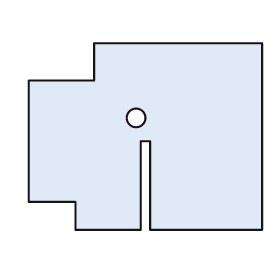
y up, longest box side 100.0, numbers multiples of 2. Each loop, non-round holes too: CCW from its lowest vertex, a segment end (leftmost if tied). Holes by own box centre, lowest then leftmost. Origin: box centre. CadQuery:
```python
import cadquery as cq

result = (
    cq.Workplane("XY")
    .moveTo(-30.0, -40.0)
    .lineTo(-2.0, -40.0)
    .lineTo(-2.0, -2.0)
    .lineTo(2.0, -2.0)
    .lineTo(2.0, -40.0)
    .lineTo(50.0, -40.0)
    .lineTo(50.0, 40.0)
    .lineTo(-22.0, 40.0)
    .lineTo(-22.0, 24.0)
    .lineTo(-50.0, 24.0)
    .lineTo(-50.0, -28.0)
    .lineTo(-30.0, -28.0)
    .close()
    .moveTo(-4.0, 8.0)
    .circle(4.0)
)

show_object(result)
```